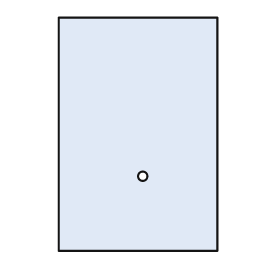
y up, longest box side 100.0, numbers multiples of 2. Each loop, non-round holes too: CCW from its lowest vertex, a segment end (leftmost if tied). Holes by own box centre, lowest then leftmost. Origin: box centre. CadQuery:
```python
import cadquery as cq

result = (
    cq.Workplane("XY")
    .moveTo(-34.0, -50.0)
    .lineTo(34.0, -50.0)
    .lineTo(34.0, 50.0)
    .lineTo(-34.0, 50.0)
    .close()
    .moveTo(2.0, -18.0)
    .circle(2.0)
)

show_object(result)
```